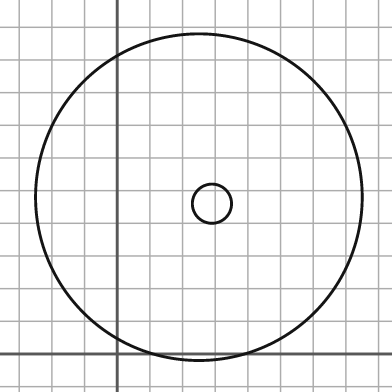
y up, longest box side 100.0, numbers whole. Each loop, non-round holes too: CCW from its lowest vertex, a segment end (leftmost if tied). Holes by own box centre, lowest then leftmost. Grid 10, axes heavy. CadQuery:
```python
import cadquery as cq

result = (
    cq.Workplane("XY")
    .moveTo(25.0, 48.0)
    .circle(50.0)
    .moveTo(29.0, 46.0)
    .circle(6.0)
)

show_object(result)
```